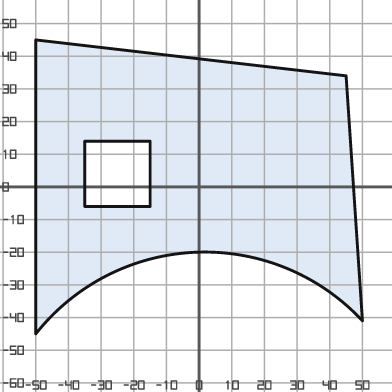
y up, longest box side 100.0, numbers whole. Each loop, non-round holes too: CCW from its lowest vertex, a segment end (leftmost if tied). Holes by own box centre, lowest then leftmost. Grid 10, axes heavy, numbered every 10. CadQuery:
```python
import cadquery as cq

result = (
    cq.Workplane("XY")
    .moveTo(-50.0, -45.0)
    .threePointArc((-1.0, -20.0), (50.0, -41.0))
    .lineTo(45.0, 34.0)
    .lineTo(-50.0, 45.0)
    .close()
    .moveTo(-35.0, -6.0)
    .lineTo(-15.0, -6.0)
    .lineTo(-15.0, 14.0)
    .lineTo(-35.0, 14.0)
    .close()
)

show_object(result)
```